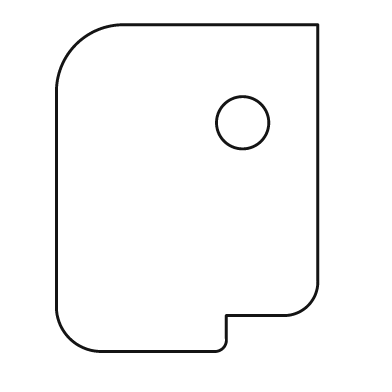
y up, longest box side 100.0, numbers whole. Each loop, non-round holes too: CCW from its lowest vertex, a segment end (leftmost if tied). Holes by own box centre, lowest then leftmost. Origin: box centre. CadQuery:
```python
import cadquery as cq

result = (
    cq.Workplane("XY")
    .moveTo(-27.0, -50.0)
    .lineTo(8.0, -50.0)
    .threePointArc((11.0, -49.0), (12.0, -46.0))
    .lineTo(12.0, -39.0)
    .lineTo(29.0, -39.0)
    .threePointArc((37.0, -36.0), (40.0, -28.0))
    .lineTo(40.0, 50.0)
    .lineTo(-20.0, 50.0)
    .threePointArc((-34.0, 44.0), (-40.0, 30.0))
    .lineTo(-40.0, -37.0)
    .threePointArc((-36.0, -46.0), (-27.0, -50.0))
    .close()
    .moveTo(17.0, 20.0)
    .circle(8.0)
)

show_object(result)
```